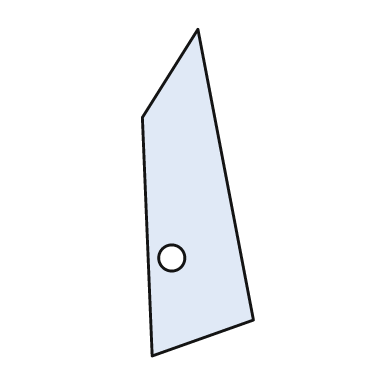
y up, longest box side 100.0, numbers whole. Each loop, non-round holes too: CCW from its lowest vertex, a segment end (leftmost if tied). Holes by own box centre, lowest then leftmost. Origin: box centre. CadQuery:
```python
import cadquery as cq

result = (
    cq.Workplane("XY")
    .moveTo(-14.0, -50.0)
    .lineTo(17.0, -39.0)
    .lineTo(0.0, 50.0)
    .lineTo(-17.0, 23.0)
    .close()
    .moveTo(-8.0, -20.0)
    .circle(4.0)
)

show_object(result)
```